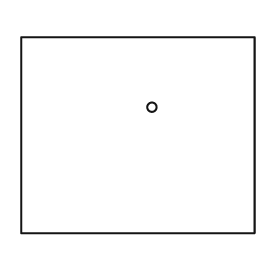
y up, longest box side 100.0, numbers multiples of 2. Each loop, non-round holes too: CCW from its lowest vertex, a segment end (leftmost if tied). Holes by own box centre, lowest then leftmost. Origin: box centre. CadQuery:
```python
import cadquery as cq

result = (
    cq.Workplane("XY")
    .moveTo(-50.0, -42.0)
    .lineTo(50.0, -42.0)
    .lineTo(50.0, 42.0)
    .lineTo(-50.0, 42.0)
    .close()
    .moveTo(6.0, 12.0)
    .circle(2.0)
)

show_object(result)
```